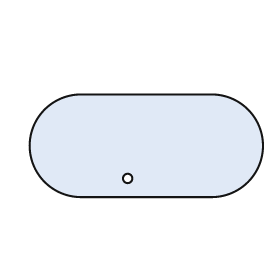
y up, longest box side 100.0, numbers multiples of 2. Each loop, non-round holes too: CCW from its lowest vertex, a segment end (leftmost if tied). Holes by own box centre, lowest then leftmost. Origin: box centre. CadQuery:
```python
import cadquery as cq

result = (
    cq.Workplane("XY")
    .moveTo(-28.0, -22.0)
    .lineTo(28.0, -22.0)
    .threePointArc((50.0, 0.0), (28.0, 22.0))
    .lineTo(-28.0, 22.0)
    .threePointArc((-50.0, 0.0), (-28.0, -22.0))
    .close()
    .moveTo(-8.0, -14.0)
    .circle(2.0)
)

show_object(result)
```